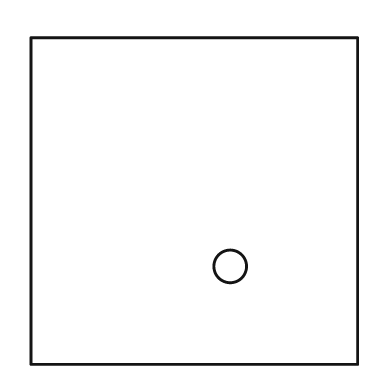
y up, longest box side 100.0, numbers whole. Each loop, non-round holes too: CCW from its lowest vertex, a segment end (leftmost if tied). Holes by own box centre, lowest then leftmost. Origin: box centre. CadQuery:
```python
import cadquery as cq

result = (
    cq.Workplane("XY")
    .moveTo(-50.0, -50.0)
    .lineTo(50.0, -50.0)
    .lineTo(50.0, 50.0)
    .lineTo(-50.0, 50.0)
    .close()
    .moveTo(11.0, -20.0)
    .circle(5.0)
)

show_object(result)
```